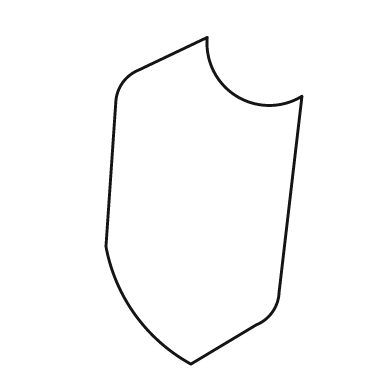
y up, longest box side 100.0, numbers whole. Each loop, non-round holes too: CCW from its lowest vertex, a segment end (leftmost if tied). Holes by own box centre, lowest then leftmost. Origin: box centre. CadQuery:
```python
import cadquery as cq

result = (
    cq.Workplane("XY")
    .moveTo(-4.0, -50.0)
    .lineTo(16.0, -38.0)
    .threePointArc((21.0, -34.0), (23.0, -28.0))
    .lineTo(30.0, 32.0)
    .threePointArc((10.0, 32.0), (1.0, 50.0))
    .lineTo(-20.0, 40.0)
    .threePointArc((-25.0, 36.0), (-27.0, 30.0))
    .lineTo(-30.0, -14.0)
    .threePointArc((-21.0, -35.0), (-4.0, -50.0))
    .close()
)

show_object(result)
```